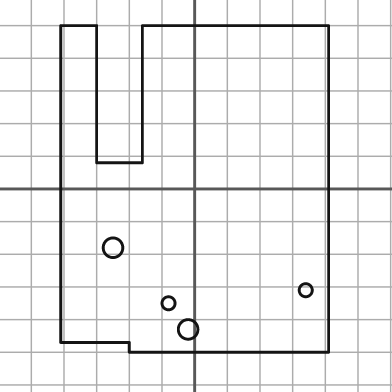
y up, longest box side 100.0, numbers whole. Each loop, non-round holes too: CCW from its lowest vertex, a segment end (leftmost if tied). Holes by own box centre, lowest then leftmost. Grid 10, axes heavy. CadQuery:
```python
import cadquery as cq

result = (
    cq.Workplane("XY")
    .moveTo(-20.0, -50.0)
    .lineTo(41.0, -50.0)
    .lineTo(41.0, 50.0)
    .lineTo(-16.0, 50.0)
    .lineTo(-16.0, 8.0)
    .lineTo(-30.0, 8.0)
    .lineTo(-30.0, 50.0)
    .lineTo(-41.0, 50.0)
    .lineTo(-41.0, -47.0)
    .lineTo(-20.0, -47.0)
    .close()
    .moveTo(-2.0, -43.0)
    .circle(3.0)
    .moveTo(-8.0, -35.0)
    .circle(2.0)
    .moveTo(34.0, -31.0)
    .circle(2.0)
    .moveTo(-25.0, -18.0)
    .circle(3.0)
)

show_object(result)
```